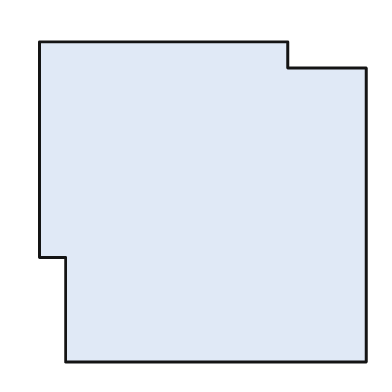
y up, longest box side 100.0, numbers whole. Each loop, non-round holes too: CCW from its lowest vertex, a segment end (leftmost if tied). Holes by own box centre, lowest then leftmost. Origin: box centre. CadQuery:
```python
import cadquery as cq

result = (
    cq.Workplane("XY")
    .moveTo(-42.0, -49.0)
    .lineTo(50.0, -49.0)
    .lineTo(50.0, 41.0)
    .lineTo(26.0, 41.0)
    .lineTo(26.0, 49.0)
    .lineTo(-50.0, 49.0)
    .lineTo(-50.0, -17.0)
    .lineTo(-42.0, -17.0)
    .close()
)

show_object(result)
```